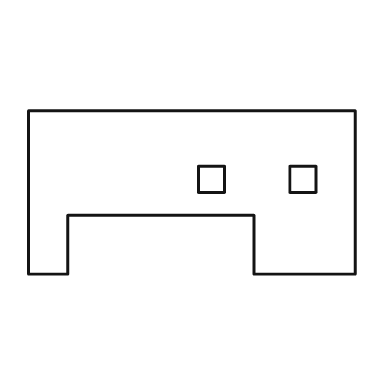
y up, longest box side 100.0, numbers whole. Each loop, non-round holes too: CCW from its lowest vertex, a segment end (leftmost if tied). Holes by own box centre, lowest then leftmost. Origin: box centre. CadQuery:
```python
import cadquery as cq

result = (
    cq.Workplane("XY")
    .moveTo(-50.0, -25.0)
    .lineTo(-38.0, -25.0)
    .lineTo(-38.0, -7.0)
    .lineTo(19.0, -7.0)
    .lineTo(19.0, -25.0)
    .lineTo(50.0, -25.0)
    .lineTo(50.0, 25.0)
    .lineTo(-50.0, 25.0)
    .close()
    .moveTo(2.0, 0.0)
    .lineTo(10.0, 0.0)
    .lineTo(10.0, 8.0)
    .lineTo(2.0, 8.0)
    .close()
    .moveTo(30.0, 0.0)
    .lineTo(38.0, 0.0)
    .lineTo(38.0, 8.0)
    .lineTo(30.0, 8.0)
    .close()
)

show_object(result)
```